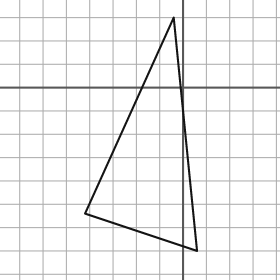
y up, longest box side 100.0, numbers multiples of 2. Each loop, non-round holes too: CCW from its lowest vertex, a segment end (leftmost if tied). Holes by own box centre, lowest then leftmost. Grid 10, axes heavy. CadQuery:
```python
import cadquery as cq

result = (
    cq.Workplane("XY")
    .moveTo(6.0, -70.0)
    .lineTo(-4.0, 30.0)
    .lineTo(-42.0, -54.0)
    .close()
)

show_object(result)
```